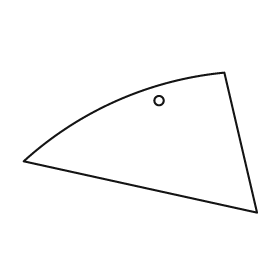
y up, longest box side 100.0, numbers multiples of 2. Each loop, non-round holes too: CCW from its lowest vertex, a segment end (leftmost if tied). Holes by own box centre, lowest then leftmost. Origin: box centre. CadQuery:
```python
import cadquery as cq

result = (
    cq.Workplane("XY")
    .moveTo(50.0, -30.0)
    .lineTo(36.0, 30.0)
    .threePointArc((-10.0, 18.0), (-50.0, -8.0))
    .close()
    .moveTo(8.0, 18.0)
    .circle(2.0)
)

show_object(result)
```